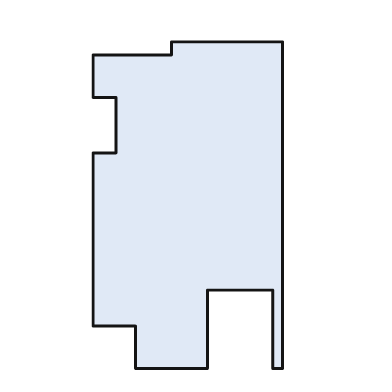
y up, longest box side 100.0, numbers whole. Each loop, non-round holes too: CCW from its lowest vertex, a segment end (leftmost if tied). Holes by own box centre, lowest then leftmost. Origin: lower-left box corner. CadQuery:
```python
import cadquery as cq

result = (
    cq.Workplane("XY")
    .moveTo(13.0, 0.0)
    .lineTo(35.0, 0.0)
    .lineTo(35.0, 24.0)
    .lineTo(55.0, 24.0)
    .lineTo(55.0, 0.0)
    .lineTo(58.0, 0.0)
    .lineTo(58.0, 100.0)
    .lineTo(24.0, 100.0)
    .lineTo(24.0, 96.0)
    .lineTo(0.0, 96.0)
    .lineTo(0.0, 83.0)
    .lineTo(7.0, 83.0)
    .lineTo(7.0, 66.0)
    .lineTo(0.0, 66.0)
    .lineTo(0.0, 13.0)
    .lineTo(13.0, 13.0)
    .close()
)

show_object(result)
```